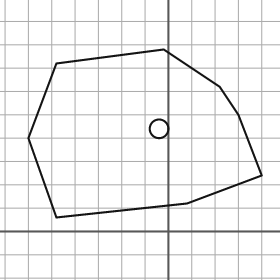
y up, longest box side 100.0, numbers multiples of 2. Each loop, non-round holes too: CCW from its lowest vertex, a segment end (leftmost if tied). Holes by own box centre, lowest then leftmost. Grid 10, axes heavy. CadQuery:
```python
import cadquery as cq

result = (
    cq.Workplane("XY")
    .moveTo(-48.0, 6.0)
    .lineTo(8.0, 12.0)
    .lineTo(40.0, 24.0)
    .lineTo(30.0, 50.0)
    .lineTo(22.0, 62.0)
    .lineTo(-2.0, 78.0)
    .lineTo(-48.0, 72.0)
    .lineTo(-60.0, 40.0)
    .close()
    .moveTo(-4.0, 44.0)
    .circle(4.0)
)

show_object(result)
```